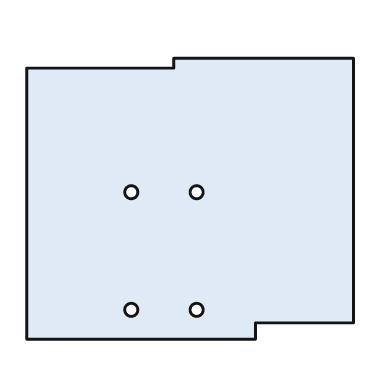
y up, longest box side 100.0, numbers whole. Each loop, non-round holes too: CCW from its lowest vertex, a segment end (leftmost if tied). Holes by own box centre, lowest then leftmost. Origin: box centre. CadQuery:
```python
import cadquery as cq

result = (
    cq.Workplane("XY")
    .moveTo(-50.0, -43.0)
    .lineTo(20.0, -43.0)
    .lineTo(20.0, -38.0)
    .lineTo(50.0, -38.0)
    .lineTo(50.0, 43.0)
    .lineTo(-5.0, 43.0)
    .lineTo(-5.0, 40.0)
    .lineTo(-50.0, 40.0)
    .close()
    .moveTo(-18.0, -34.0)
    .circle(2.0)
    .moveTo(2.0, -34.0)
    .circle(2.0)
    .moveTo(-18.0, 2.0)
    .circle(2.0)
    .moveTo(2.0, 2.0)
    .circle(2.0)
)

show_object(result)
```